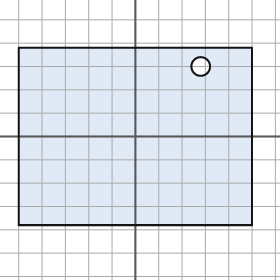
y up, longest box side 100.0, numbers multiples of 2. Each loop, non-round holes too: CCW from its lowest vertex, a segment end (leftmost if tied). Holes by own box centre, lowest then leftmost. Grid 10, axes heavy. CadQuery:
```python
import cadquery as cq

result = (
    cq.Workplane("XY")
    .moveTo(-50.0, -38.0)
    .lineTo(50.0, -38.0)
    .lineTo(50.0, 38.0)
    .lineTo(-50.0, 38.0)
    .close()
    .moveTo(28.0, 30.0)
    .circle(4.0)
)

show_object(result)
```